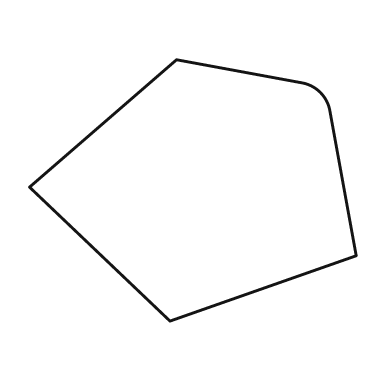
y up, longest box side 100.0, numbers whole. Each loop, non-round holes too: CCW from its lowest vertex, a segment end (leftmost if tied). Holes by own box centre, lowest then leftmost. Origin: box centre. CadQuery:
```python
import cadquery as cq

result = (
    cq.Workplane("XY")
    .moveTo(-7.0, -40.0)
    .lineTo(50.0, -20.0)
    .lineTo(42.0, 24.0)
    .threePointArc((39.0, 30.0), (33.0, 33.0))
    .lineTo(-5.0, 40.0)
    .lineTo(-50.0, 1.0)
    .close()
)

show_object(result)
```